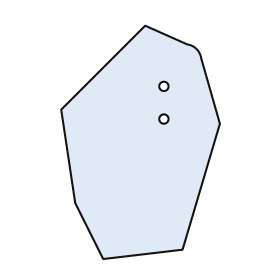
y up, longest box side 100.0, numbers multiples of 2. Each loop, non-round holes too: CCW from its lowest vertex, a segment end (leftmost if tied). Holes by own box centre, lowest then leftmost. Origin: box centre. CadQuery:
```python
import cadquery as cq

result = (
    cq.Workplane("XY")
    .moveTo(-16.0, -50.0)
    .lineTo(18.0, -46.0)
    .lineTo(34.0, 8.0)
    .lineTo(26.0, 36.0)
    .threePointArc((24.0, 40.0), (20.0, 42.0))
    .lineTo(2.0, 50.0)
    .lineTo(-34.0, 14.0)
    .lineTo(-28.0, -26.0)
    .close()
    .moveTo(10.0, 10.0)
    .circle(2.0)
    .moveTo(10.0, 24.0)
    .circle(2.0)
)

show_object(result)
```